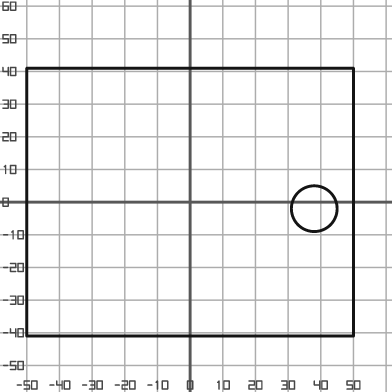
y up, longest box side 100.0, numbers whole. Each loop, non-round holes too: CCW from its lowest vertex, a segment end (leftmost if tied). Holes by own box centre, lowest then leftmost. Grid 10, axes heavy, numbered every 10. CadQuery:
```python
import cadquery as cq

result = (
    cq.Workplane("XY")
    .moveTo(-50.0, -41.0)
    .lineTo(50.0, -41.0)
    .lineTo(50.0, 41.0)
    .lineTo(-50.0, 41.0)
    .close()
    .moveTo(38.0, -2.0)
    .circle(7.0)
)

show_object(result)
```